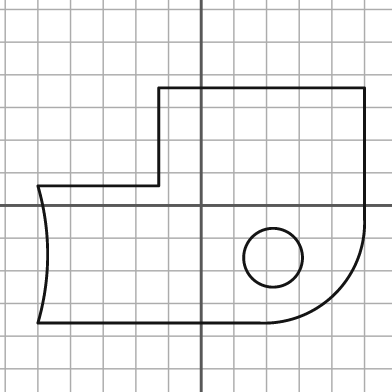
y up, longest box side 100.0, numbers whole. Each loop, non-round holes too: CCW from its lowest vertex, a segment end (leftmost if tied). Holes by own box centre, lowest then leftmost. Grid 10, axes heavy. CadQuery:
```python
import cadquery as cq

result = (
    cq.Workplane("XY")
    .moveTo(-50.0, -36.0)
    .lineTo(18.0, -36.0)
    .threePointArc((41.0, -27.0), (50.0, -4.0))
    .lineTo(50.0, 36.0)
    .lineTo(-13.0, 36.0)
    .lineTo(-13.0, 6.0)
    .lineTo(-50.0, 6.0)
    .threePointArc((-47.0, -15.0), (-50.0, -36.0))
    .close()
    .moveTo(22.0, -16.0)
    .circle(9.0)
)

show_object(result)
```